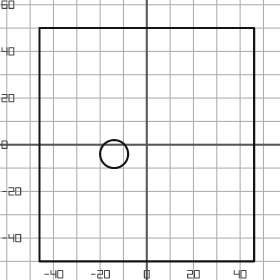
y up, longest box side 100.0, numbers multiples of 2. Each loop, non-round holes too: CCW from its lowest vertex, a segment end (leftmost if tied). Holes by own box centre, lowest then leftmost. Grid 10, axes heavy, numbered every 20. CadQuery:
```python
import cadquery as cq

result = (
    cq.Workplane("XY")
    .moveTo(-46.0, -50.0)
    .lineTo(46.0, -50.0)
    .lineTo(46.0, 50.0)
    .lineTo(-46.0, 50.0)
    .close()
    .moveTo(-14.0, -4.0)
    .circle(6.0)
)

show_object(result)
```